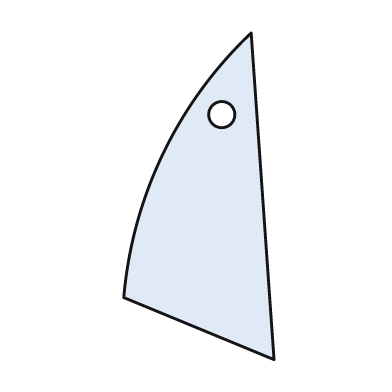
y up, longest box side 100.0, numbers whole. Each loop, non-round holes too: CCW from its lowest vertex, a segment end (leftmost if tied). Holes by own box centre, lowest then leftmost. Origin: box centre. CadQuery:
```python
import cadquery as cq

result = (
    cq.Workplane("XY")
    .moveTo(23.0, -50.0)
    .lineTo(16.0, 50.0)
    .threePointArc((-11.0, 13.0), (-23.0, -31.0))
    .close()
    .moveTo(7.0, 25.0)
    .circle(4.0)
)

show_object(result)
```